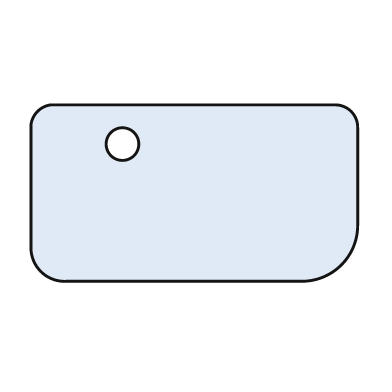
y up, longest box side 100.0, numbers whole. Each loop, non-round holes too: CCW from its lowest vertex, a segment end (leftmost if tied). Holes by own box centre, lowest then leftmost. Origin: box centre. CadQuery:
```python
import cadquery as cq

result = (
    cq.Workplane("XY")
    .moveTo(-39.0, -27.0)
    .lineTo(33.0, -27.0)
    .threePointArc((45.0, -22.0), (50.0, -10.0))
    .lineTo(50.0, 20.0)
    .threePointArc((48.0, 25.0), (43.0, 27.0))
    .lineTo(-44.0, 27.0)
    .threePointArc((-48.0, 25.0), (-50.0, 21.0))
    .lineTo(-50.0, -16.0)
    .threePointArc((-47.0, -24.0), (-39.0, -27.0))
    .close()
    .moveTo(-22.0, 15.0)
    .circle(5.0)
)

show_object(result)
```